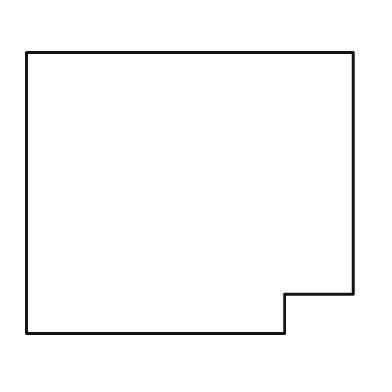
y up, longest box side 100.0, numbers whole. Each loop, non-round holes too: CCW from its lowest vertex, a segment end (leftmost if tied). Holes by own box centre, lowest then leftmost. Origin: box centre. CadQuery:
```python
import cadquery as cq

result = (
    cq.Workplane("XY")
    .moveTo(-50.0, -43.0)
    .lineTo(29.0, -43.0)
    .lineTo(29.0, -31.0)
    .lineTo(50.0, -31.0)
    .lineTo(50.0, 43.0)
    .lineTo(-50.0, 43.0)
    .close()
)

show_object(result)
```